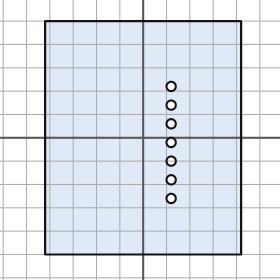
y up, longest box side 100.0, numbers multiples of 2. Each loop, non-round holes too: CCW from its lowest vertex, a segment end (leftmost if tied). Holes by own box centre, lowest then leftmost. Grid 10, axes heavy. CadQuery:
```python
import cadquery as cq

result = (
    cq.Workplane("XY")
    .moveTo(-42.0, -50.0)
    .lineTo(42.0, -50.0)
    .lineTo(42.0, 50.0)
    .lineTo(-42.0, 50.0)
    .close()
    .moveTo(12.0, -26.0)
    .circle(2.0)
    .moveTo(12.0, -18.0)
    .circle(2.0)
    .moveTo(12.0, -10.0)
    .circle(2.0)
    .moveTo(12.0, -2.0)
    .circle(2.0)
    .moveTo(12.0, 6.0)
    .circle(2.0)
    .moveTo(12.0, 14.0)
    .circle(2.0)
    .moveTo(12.0, 22.0)
    .circle(2.0)
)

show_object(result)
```